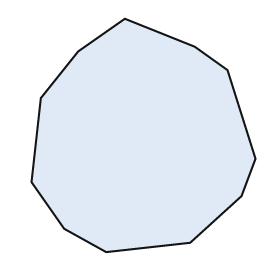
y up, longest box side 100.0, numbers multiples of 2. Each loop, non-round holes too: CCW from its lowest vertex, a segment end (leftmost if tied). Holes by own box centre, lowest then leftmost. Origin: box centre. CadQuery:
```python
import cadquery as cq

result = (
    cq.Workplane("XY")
    .moveTo(-16.0, -50.0)
    .lineTo(20.0, -46.0)
    .lineTo(42.0, -26.0)
    .lineTo(48.0, -10.0)
    .lineTo(36.0, 28.0)
    .lineTo(22.0, 38.0)
    .lineTo(-8.0, 50.0)
    .lineTo(-28.0, 36.0)
    .lineTo(-44.0, 16.0)
    .lineTo(-48.0, -20.0)
    .lineTo(-34.0, -40.0)
    .close()
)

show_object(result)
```